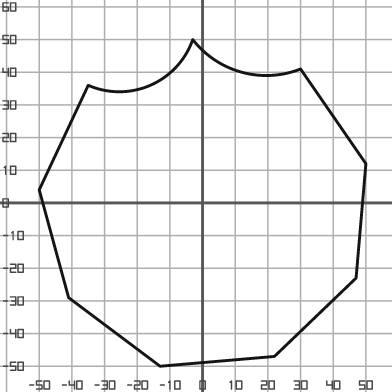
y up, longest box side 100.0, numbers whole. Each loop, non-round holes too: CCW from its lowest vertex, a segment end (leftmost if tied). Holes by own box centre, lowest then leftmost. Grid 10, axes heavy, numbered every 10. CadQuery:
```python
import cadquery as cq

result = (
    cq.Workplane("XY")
    .moveTo(-13.0, -50.0)
    .lineTo(22.0, -47.0)
    .lineTo(47.0, -23.0)
    .lineTo(50.0, 12.0)
    .lineTo(30.0, 41.0)
    .threePointArc((12.0, 40.0), (-3.0, 50.0))
    .threePointArc((-16.0, 36.0), (-35.0, 36.0))
    .lineTo(-50.0, 4.0)
    .lineTo(-41.0, -29.0)
    .close()
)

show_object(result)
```